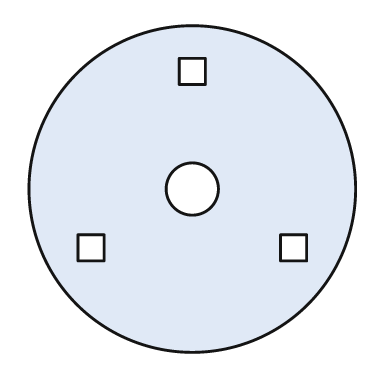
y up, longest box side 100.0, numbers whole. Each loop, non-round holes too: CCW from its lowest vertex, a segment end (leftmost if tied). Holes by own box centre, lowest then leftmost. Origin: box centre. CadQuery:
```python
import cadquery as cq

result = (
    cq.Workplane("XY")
    .moveTo(0.0, 0.0)
    .circle(50.0)
    .moveTo(-35.0, -22.0)
    .lineTo(-27.0, -22.0)
    .lineTo(-27.0, -14.0)
    .lineTo(-35.0, -14.0)
    .close()
    .moveTo(27.0, -22.0)
    .lineTo(35.0, -22.0)
    .lineTo(35.0, -14.0)
    .lineTo(27.0, -14.0)
    .close()
    .moveTo(0.0, 0.0)
    .circle(8.0)
    .moveTo(-4.0, 32.0)
    .lineTo(4.0, 32.0)
    .lineTo(4.0, 40.0)
    .lineTo(-4.0, 40.0)
    .close()
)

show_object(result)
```